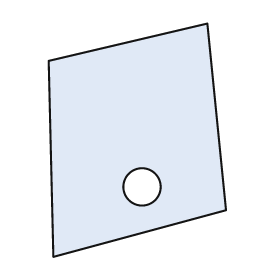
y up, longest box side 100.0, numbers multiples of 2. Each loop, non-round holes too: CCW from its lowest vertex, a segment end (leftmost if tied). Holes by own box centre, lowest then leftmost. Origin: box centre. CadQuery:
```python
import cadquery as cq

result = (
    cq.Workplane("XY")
    .moveTo(-36.0, -50.0)
    .lineTo(38.0, -30.0)
    .lineTo(30.0, 50.0)
    .lineTo(-38.0, 34.0)
    .close()
    .moveTo(2.0, -20.0)
    .circle(8.0)
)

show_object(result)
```